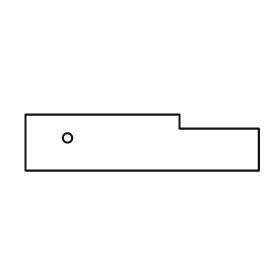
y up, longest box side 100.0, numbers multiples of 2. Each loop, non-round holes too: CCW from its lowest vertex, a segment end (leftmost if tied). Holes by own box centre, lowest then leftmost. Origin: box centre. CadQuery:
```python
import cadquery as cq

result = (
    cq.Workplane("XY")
    .moveTo(-50.0, -12.0)
    .lineTo(50.0, -12.0)
    .lineTo(50.0, 6.0)
    .lineTo(16.0, 6.0)
    .lineTo(16.0, 12.0)
    .lineTo(-50.0, 12.0)
    .close()
    .moveTo(-32.0, 2.0)
    .circle(2.0)
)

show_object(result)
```